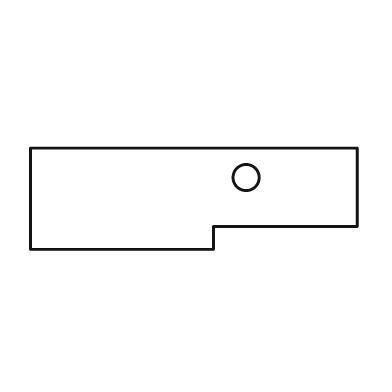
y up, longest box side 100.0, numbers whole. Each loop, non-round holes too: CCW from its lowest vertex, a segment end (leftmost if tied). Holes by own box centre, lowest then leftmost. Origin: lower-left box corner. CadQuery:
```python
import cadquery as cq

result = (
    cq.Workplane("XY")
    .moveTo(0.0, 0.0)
    .lineTo(56.0, 0.0)
    .lineTo(56.0, 7.0)
    .lineTo(100.0, 7.0)
    .lineTo(100.0, 31.0)
    .lineTo(0.0, 31.0)
    .close()
    .moveTo(66.0, 22.0)
    .circle(4.0)
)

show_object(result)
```